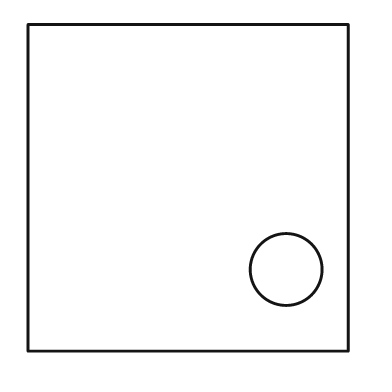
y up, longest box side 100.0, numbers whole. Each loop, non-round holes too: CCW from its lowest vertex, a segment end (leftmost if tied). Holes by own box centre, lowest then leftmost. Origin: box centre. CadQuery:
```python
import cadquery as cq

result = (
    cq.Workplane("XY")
    .moveTo(-49.0, -50.0)
    .lineTo(49.0, -50.0)
    .lineTo(49.0, 50.0)
    .lineTo(-49.0, 50.0)
    .close()
    .moveTo(30.0, -25.0)
    .circle(11.0)
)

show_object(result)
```